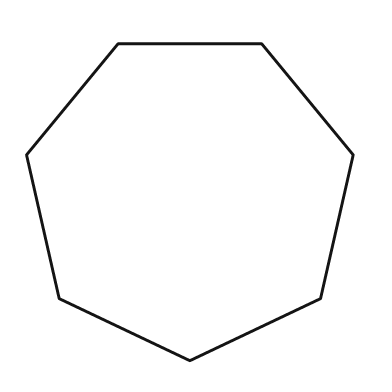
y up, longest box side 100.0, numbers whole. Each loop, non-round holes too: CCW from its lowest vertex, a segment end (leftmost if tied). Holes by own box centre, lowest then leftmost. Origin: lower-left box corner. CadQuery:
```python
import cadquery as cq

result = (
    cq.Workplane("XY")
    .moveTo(50.0, 0.0)
    .lineTo(90.0, 19.0)
    .lineTo(100.0, 63.0)
    .lineTo(72.0, 97.0)
    .lineTo(28.0, 97.0)
    .lineTo(0.0, 63.0)
    .lineTo(10.0, 19.0)
    .close()
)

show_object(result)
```